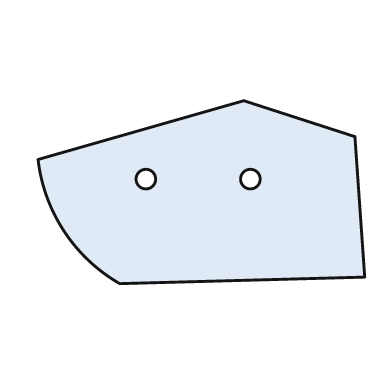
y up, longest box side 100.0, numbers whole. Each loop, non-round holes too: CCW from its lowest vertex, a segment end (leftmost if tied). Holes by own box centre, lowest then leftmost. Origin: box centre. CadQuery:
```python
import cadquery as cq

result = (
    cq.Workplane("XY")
    .moveTo(-25.0, -28.0)
    .lineTo(50.0, -26.0)
    .lineTo(47.0, 17.0)
    .lineTo(13.0, 28.0)
    .lineTo(-50.0, 10.0)
    .threePointArc((-42.0, -12.0), (-25.0, -28.0))
    .close()
    .moveTo(-17.0, 4.0)
    .circle(3.0)
    .moveTo(15.0, 4.0)
    .circle(3.0)
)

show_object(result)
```